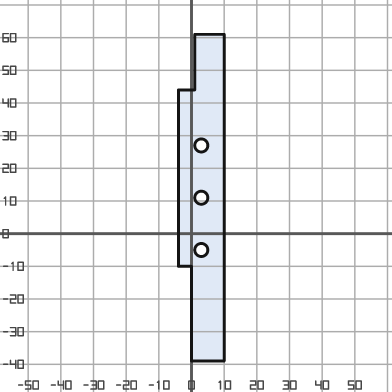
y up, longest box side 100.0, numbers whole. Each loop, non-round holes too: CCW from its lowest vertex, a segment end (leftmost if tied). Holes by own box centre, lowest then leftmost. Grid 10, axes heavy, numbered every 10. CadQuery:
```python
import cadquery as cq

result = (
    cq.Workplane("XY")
    .moveTo(0.0, -39.0)
    .lineTo(10.0, -39.0)
    .lineTo(10.0, 61.0)
    .lineTo(1.0, 61.0)
    .lineTo(1.0, 44.0)
    .lineTo(-4.0, 44.0)
    .lineTo(-4.0, -10.0)
    .lineTo(0.0, -10.0)
    .close()
    .moveTo(3.0, -5.0)
    .circle(2.0)
    .moveTo(3.0, 11.0)
    .circle(2.0)
    .moveTo(3.0, 27.0)
    .circle(2.0)
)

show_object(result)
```